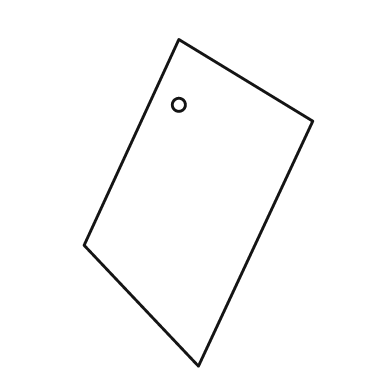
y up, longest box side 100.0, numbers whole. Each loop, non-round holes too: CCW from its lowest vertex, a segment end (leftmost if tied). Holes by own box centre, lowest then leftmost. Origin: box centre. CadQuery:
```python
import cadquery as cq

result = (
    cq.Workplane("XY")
    .moveTo(0.0, -50.0)
    .lineTo(35.0, 25.0)
    .lineTo(-6.0, 50.0)
    .lineTo(-35.0, -13.0)
    .close()
    .moveTo(-6.0, 30.0)
    .circle(2.0)
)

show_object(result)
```